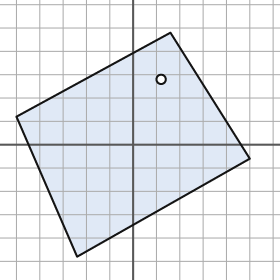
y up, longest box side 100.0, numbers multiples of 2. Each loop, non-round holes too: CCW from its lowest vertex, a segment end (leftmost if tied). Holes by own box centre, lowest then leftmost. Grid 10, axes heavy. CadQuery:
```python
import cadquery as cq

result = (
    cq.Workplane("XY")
    .moveTo(-24.0, -48.0)
    .lineTo(50.0, -6.0)
    .lineTo(16.0, 48.0)
    .lineTo(-50.0, 12.0)
    .close()
    .moveTo(12.0, 28.0)
    .circle(2.0)
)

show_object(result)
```